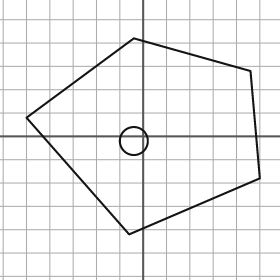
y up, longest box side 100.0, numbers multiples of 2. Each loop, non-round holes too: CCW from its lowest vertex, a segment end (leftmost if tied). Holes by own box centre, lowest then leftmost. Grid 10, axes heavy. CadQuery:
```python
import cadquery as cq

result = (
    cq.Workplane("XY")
    .moveTo(-6.0, -42.0)
    .lineTo(50.0, -18.0)
    .lineTo(46.0, 28.0)
    .lineTo(-4.0, 42.0)
    .lineTo(-50.0, 8.0)
    .close()
    .moveTo(-4.0, -2.0)
    .circle(6.0)
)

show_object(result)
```